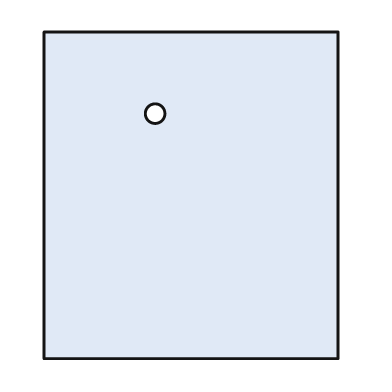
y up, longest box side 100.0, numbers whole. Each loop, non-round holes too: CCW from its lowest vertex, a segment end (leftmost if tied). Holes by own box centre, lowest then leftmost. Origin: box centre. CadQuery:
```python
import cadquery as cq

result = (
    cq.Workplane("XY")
    .moveTo(-45.0, -50.0)
    .lineTo(45.0, -50.0)
    .lineTo(45.0, 50.0)
    .lineTo(-45.0, 50.0)
    .close()
    .moveTo(-11.0, 25.0)
    .circle(3.0)
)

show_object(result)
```